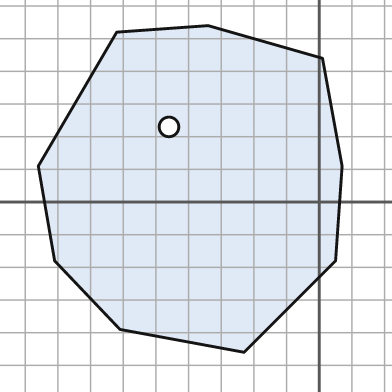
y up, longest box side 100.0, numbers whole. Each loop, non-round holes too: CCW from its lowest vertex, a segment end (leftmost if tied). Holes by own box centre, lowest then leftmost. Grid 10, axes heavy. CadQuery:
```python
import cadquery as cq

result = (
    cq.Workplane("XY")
    .moveTo(-23.0, -46.0)
    .lineTo(5.0, -18.0)
    .lineTo(7.0, 11.0)
    .lineTo(1.0, 44.0)
    .lineTo(-34.0, 54.0)
    .lineTo(-62.0, 52.0)
    .lineTo(-86.0, 11.0)
    .lineTo(-81.0, -18.0)
    .lineTo(-61.0, -39.0)
    .close()
    .moveTo(-46.0, 23.0)
    .circle(3.0)
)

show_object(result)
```